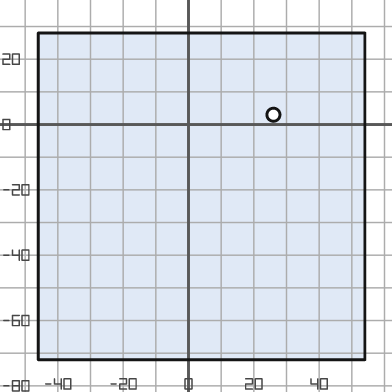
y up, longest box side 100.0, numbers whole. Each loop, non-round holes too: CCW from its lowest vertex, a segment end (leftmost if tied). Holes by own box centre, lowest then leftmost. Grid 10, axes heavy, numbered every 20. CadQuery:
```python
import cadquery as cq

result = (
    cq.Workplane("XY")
    .moveTo(-46.0, -72.0)
    .lineTo(54.0, -72.0)
    .lineTo(54.0, 28.0)
    .lineTo(-46.0, 28.0)
    .close()
    .moveTo(26.0, 3.0)
    .circle(2.0)
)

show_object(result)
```